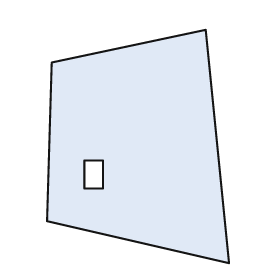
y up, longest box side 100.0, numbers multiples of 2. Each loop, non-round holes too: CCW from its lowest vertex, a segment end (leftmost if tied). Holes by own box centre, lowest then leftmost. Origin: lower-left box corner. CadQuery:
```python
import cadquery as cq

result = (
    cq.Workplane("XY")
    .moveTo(78.0, 0.0)
    .lineTo(68.0, 100.0)
    .lineTo(2.0, 86.0)
    .lineTo(0.0, 18.0)
    .close()
    .moveTo(16.0, 32.0)
    .lineTo(24.0, 32.0)
    .lineTo(24.0, 44.0)
    .lineTo(16.0, 44.0)
    .close()
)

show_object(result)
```